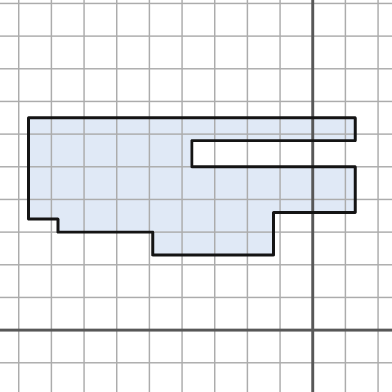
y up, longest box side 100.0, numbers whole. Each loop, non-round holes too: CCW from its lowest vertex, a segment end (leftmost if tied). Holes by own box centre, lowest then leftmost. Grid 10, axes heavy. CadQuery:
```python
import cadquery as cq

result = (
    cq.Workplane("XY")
    .moveTo(-49.0, 23.0)
    .lineTo(-12.0, 23.0)
    .lineTo(-12.0, 36.0)
    .lineTo(13.0, 36.0)
    .lineTo(13.0, 50.0)
    .lineTo(-37.0, 50.0)
    .lineTo(-37.0, 58.0)
    .lineTo(13.0, 58.0)
    .lineTo(13.0, 65.0)
    .lineTo(-87.0, 65.0)
    .lineTo(-87.0, 34.0)
    .lineTo(-78.0, 34.0)
    .lineTo(-78.0, 30.0)
    .lineTo(-49.0, 30.0)
    .close()
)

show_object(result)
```